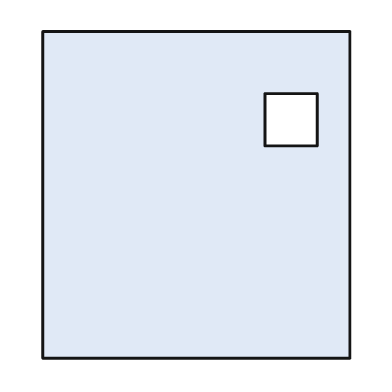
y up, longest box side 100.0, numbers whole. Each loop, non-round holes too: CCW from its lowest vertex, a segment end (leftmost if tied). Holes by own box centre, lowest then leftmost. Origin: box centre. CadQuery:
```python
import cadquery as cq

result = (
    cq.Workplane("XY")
    .moveTo(-47.0, -50.0)
    .lineTo(47.0, -50.0)
    .lineTo(47.0, 50.0)
    .lineTo(-47.0, 50.0)
    .close()
    .moveTo(21.0, 15.0)
    .lineTo(37.0, 15.0)
    .lineTo(37.0, 31.0)
    .lineTo(21.0, 31.0)
    .close()
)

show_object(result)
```